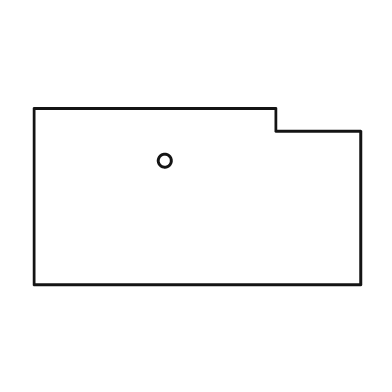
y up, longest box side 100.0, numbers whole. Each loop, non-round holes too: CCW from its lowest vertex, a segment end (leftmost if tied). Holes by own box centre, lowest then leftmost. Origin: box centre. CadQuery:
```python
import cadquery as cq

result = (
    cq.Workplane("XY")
    .moveTo(-50.0, -27.0)
    .lineTo(50.0, -27.0)
    .lineTo(50.0, 20.0)
    .lineTo(24.0, 20.0)
    .lineTo(24.0, 27.0)
    .lineTo(-50.0, 27.0)
    .close()
    .moveTo(-10.0, 11.0)
    .circle(2.0)
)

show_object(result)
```